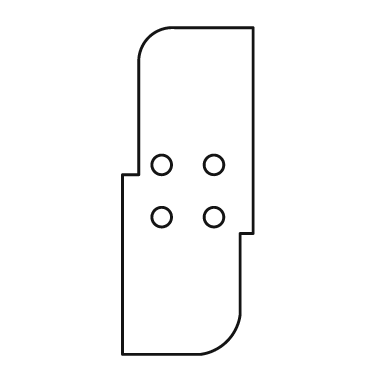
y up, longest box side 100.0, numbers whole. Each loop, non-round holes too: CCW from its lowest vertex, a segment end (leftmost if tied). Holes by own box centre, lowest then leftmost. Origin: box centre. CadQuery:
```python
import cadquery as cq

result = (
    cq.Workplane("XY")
    .moveTo(-20.0, -50.0)
    .lineTo(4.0, -50.0)
    .threePointArc((12.0, -46.0), (16.0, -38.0))
    .lineTo(16.0, -13.0)
    .lineTo(20.0, -13.0)
    .lineTo(20.0, 50.0)
    .lineTo(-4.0, 50.0)
    .threePointArc((-12.0, 47.0), (-15.0, 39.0))
    .lineTo(-15.0, 5.0)
    .lineTo(-20.0, 5.0)
    .close()
    .moveTo(-8.0, -8.0)
    .circle(3.0)
    .moveTo(8.0, -8.0)
    .circle(3.0)
    .moveTo(-8.0, 8.0)
    .circle(3.0)
    .moveTo(8.0, 8.0)
    .circle(3.0)
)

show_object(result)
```